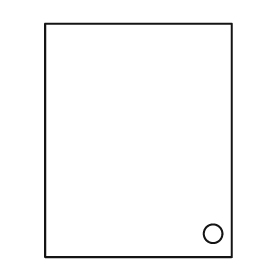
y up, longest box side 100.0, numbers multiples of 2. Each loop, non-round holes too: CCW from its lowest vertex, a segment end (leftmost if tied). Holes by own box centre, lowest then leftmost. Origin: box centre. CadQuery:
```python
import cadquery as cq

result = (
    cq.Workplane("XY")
    .moveTo(-40.0, -50.0)
    .lineTo(40.0, -50.0)
    .lineTo(40.0, 50.0)
    .lineTo(-40.0, 50.0)
    .close()
    .moveTo(32.0, -40.0)
    .circle(4.0)
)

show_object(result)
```